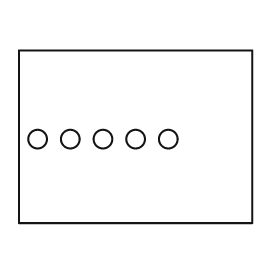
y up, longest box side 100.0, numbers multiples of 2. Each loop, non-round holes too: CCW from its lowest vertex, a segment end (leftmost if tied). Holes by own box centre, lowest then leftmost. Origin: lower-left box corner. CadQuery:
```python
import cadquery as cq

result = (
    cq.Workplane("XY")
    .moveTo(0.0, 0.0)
    .lineTo(100.0, 0.0)
    .lineTo(100.0, 74.0)
    .lineTo(0.0, 74.0)
    .close()
    .moveTo(8.0, 36.0)
    .circle(4.0)
    .moveTo(22.0, 36.0)
    .circle(4.0)
    .moveTo(36.0, 36.0)
    .circle(4.0)
    .moveTo(50.0, 36.0)
    .circle(4.0)
    .moveTo(64.0, 36.0)
    .circle(4.0)
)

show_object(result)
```